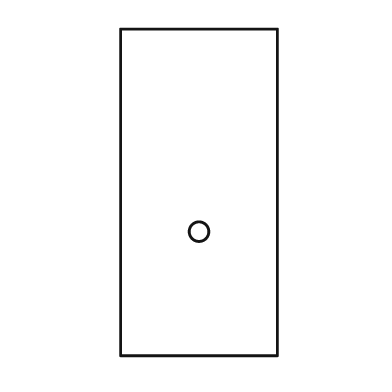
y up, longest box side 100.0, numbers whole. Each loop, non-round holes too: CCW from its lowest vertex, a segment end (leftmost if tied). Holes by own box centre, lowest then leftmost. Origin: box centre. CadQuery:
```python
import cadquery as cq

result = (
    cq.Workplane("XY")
    .moveTo(-24.0, -50.0)
    .lineTo(24.0, -50.0)
    .lineTo(24.0, 50.0)
    .lineTo(-24.0, 50.0)
    .close()
    .moveTo(0.0, -12.0)
    .circle(3.0)
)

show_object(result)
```